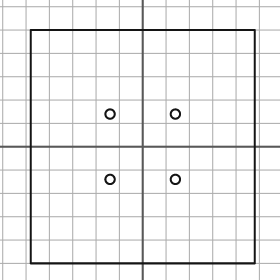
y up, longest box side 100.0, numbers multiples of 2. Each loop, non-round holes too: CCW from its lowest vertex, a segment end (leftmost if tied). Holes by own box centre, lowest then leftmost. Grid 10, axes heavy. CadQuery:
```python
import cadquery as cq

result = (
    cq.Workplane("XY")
    .moveTo(-48.0, -50.0)
    .lineTo(48.0, -50.0)
    .lineTo(48.0, 50.0)
    .lineTo(-48.0, 50.0)
    .close()
    .moveTo(-14.0, -14.0)
    .circle(2.0)
    .moveTo(14.0, -14.0)
    .circle(2.0)
    .moveTo(-14.0, 14.0)
    .circle(2.0)
    .moveTo(14.0, 14.0)
    .circle(2.0)
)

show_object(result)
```